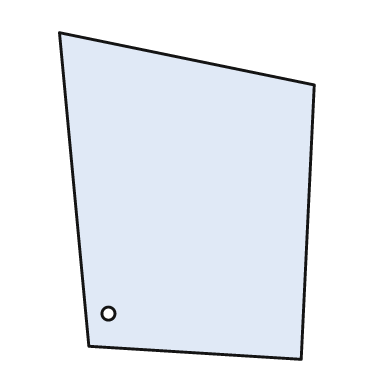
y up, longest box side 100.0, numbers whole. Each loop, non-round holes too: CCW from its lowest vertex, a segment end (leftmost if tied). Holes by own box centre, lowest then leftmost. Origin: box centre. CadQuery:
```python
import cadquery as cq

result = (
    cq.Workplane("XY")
    .moveTo(35.0, -50.0)
    .lineTo(39.0, 34.0)
    .lineTo(-39.0, 50.0)
    .lineTo(-30.0, -46.0)
    .close()
    .moveTo(-24.0, -36.0)
    .circle(2.0)
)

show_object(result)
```